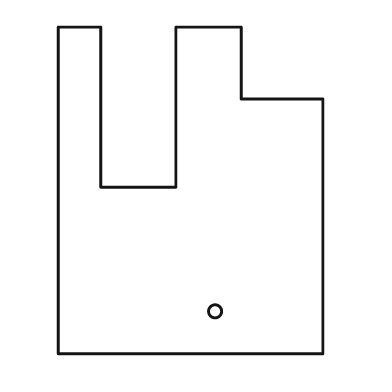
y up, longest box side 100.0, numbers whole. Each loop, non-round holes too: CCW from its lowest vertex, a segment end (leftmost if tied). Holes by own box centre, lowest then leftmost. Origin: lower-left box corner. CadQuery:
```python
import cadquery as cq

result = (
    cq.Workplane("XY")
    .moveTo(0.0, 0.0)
    .lineTo(81.0, 0.0)
    .lineTo(81.0, 78.0)
    .lineTo(56.0, 78.0)
    .lineTo(56.0, 100.0)
    .lineTo(36.0, 100.0)
    .lineTo(36.0, 51.0)
    .lineTo(13.0, 51.0)
    .lineTo(13.0, 100.0)
    .lineTo(0.0, 100.0)
    .close()
    .moveTo(48.0, 13.0)
    .circle(2.0)
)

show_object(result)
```